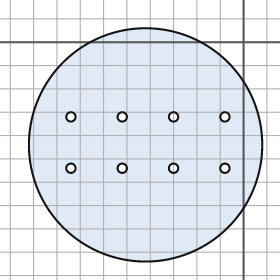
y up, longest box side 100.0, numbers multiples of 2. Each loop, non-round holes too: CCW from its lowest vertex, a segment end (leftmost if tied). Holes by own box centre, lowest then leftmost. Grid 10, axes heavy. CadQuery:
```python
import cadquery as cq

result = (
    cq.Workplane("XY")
    .moveTo(-42.0, -44.0)
    .circle(50.0)
    .moveTo(-74.0, -54.0)
    .circle(2.0)
    .moveTo(-52.0, -54.0)
    .circle(2.0)
    .moveTo(-30.0, -54.0)
    .circle(2.0)
    .moveTo(-8.0, -54.0)
    .circle(2.0)
    .moveTo(-74.0, -32.0)
    .circle(2.0)
    .moveTo(-52.0, -32.0)
    .circle(2.0)
    .moveTo(-30.0, -32.0)
    .circle(2.0)
    .moveTo(-8.0, -32.0)
    .circle(2.0)
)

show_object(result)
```